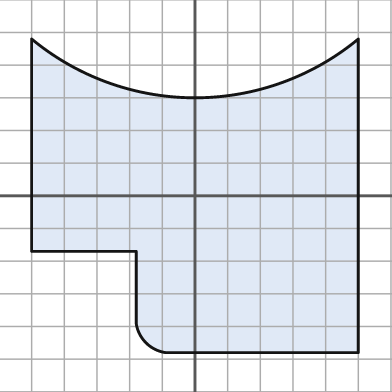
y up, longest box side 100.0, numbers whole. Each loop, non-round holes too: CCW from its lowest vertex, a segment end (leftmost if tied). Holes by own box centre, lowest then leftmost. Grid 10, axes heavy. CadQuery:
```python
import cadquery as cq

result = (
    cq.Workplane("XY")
    .moveTo(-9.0, -48.0)
    .lineTo(50.0, -48.0)
    .lineTo(50.0, 48.0)
    .threePointArc((0.0, 30.0), (-50.0, 48.0))
    .lineTo(-50.0, -17.0)
    .lineTo(-18.0, -17.0)
    .lineTo(-18.0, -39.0)
    .threePointArc((-15.0, -45.0), (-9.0, -48.0))
    .close()
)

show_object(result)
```